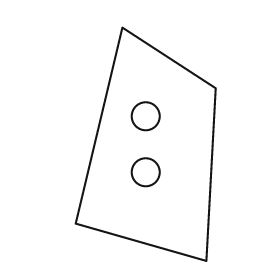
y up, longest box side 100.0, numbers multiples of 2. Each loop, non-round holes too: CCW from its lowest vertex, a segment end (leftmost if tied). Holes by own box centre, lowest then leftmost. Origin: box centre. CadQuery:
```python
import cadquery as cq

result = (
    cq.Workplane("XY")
    .moveTo(26.0, -50.0)
    .lineTo(30.0, 24.0)
    .lineTo(-10.0, 50.0)
    .lineTo(-30.0, -34.0)
    .close()
    .moveTo(0.0, -12.0)
    .circle(6.0)
    .moveTo(0.0, 12.0)
    .circle(6.0)
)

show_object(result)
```